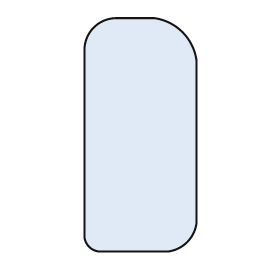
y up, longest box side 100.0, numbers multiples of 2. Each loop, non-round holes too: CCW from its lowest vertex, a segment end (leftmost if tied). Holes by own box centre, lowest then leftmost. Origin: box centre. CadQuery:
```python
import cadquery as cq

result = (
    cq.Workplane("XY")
    .moveTo(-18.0, -50.0)
    .lineTo(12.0, -50.0)
    .threePointArc((20.0, -46.0), (24.0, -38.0))
    .lineTo(24.0, 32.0)
    .threePointArc((18.0, 44.0), (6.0, 50.0))
    .lineTo(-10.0, 50.0)
    .threePointArc((-20.0, 46.0), (-24.0, 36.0))
    .lineTo(-24.0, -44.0)
    .threePointArc((-22.0, -48.0), (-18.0, -50.0))
    .close()
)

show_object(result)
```